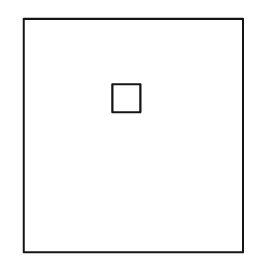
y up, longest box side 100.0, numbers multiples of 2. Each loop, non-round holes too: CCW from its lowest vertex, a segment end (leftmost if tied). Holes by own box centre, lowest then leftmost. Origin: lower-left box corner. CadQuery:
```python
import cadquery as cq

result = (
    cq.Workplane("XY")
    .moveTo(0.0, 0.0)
    .lineTo(94.0, 0.0)
    .lineTo(94.0, 100.0)
    .lineTo(0.0, 100.0)
    .close()
    .moveTo(38.0, 60.0)
    .lineTo(50.0, 60.0)
    .lineTo(50.0, 72.0)
    .lineTo(38.0, 72.0)
    .close()
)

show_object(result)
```